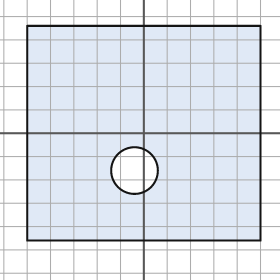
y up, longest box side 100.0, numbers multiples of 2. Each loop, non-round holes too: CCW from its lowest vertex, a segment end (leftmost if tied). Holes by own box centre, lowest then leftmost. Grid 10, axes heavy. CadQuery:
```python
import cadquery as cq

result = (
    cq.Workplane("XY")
    .moveTo(-50.0, -46.0)
    .lineTo(50.0, -46.0)
    .lineTo(50.0, 46.0)
    .lineTo(-50.0, 46.0)
    .close()
    .moveTo(-4.0, -16.0)
    .circle(10.0)
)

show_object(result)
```